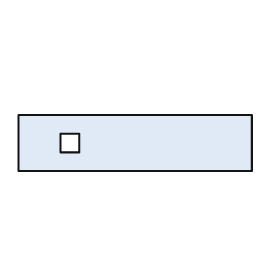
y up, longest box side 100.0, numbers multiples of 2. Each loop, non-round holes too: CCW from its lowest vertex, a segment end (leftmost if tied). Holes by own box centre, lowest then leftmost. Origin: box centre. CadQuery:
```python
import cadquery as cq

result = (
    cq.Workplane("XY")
    .moveTo(-50.0, -12.0)
    .lineTo(50.0, -12.0)
    .lineTo(50.0, 12.0)
    .lineTo(-50.0, 12.0)
    .close()
    .moveTo(-32.0, -4.0)
    .lineTo(-24.0, -4.0)
    .lineTo(-24.0, 4.0)
    .lineTo(-32.0, 4.0)
    .close()
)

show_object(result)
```